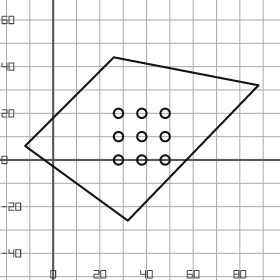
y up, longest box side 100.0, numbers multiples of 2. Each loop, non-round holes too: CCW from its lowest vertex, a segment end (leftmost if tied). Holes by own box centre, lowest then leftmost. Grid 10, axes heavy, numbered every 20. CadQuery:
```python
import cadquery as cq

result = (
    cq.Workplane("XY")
    .moveTo(32.0, -26.0)
    .lineTo(88.0, 32.0)
    .lineTo(26.0, 44.0)
    .lineTo(-12.0, 6.0)
    .close()
    .moveTo(28.0, 0.0)
    .circle(2.0)
    .moveTo(38.0, 0.0)
    .circle(2.0)
    .moveTo(48.0, 0.0)
    .circle(2.0)
    .moveTo(28.0, 10.0)
    .circle(2.0)
    .moveTo(38.0, 10.0)
    .circle(2.0)
    .moveTo(48.0, 10.0)
    .circle(2.0)
    .moveTo(28.0, 20.0)
    .circle(2.0)
    .moveTo(38.0, 20.0)
    .circle(2.0)
    .moveTo(48.0, 20.0)
    .circle(2.0)
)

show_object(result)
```